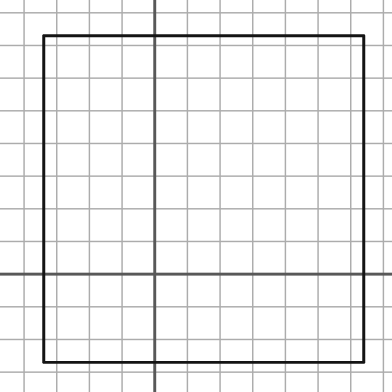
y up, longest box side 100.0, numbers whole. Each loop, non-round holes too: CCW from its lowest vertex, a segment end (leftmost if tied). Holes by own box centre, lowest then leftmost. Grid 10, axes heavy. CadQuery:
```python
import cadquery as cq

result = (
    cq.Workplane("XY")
    .moveTo(-34.0, -27.0)
    .lineTo(64.0, -27.0)
    .lineTo(64.0, 73.0)
    .lineTo(-34.0, 73.0)
    .close()
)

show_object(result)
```